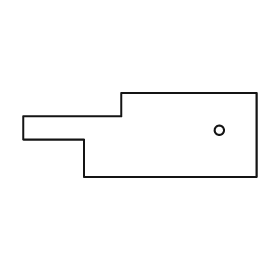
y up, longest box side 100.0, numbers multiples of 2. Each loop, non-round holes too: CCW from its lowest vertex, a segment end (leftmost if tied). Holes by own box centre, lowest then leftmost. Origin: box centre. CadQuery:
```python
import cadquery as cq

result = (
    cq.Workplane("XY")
    .moveTo(-24.0, -18.0)
    .lineTo(50.0, -18.0)
    .lineTo(50.0, 18.0)
    .lineTo(-8.0, 18.0)
    .lineTo(-8.0, 8.0)
    .lineTo(-50.0, 8.0)
    .lineTo(-50.0, -2.0)
    .lineTo(-24.0, -2.0)
    .close()
    .moveTo(34.0, 2.0)
    .circle(2.0)
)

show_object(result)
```